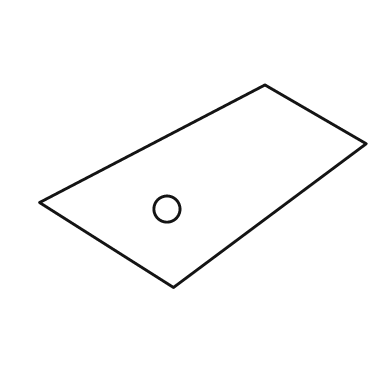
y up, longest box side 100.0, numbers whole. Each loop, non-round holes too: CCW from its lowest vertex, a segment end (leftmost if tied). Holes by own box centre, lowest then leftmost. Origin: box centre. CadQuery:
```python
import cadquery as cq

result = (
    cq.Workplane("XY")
    .moveTo(-9.0, -31.0)
    .lineTo(50.0, 13.0)
    .lineTo(19.0, 31.0)
    .lineTo(-50.0, -5.0)
    .close()
    .moveTo(-11.0, -7.0)
    .circle(4.0)
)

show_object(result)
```